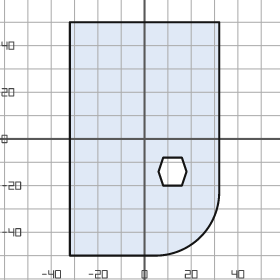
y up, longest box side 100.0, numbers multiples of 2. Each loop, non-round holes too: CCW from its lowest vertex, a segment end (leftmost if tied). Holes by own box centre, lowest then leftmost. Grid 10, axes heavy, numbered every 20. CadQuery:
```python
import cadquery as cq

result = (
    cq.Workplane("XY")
    .moveTo(-32.0, -50.0)
    .lineTo(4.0, -50.0)
    .threePointArc((24.0, -42.0), (32.0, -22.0))
    .lineTo(32.0, 50.0)
    .lineTo(-32.0, 50.0)
    .close()
    .moveTo(8.0, -20.0)
    .lineTo(16.0, -20.0)
    .lineTo(18.0, -14.0)
    .lineTo(16.0, -8.0)
    .lineTo(8.0, -8.0)
    .lineTo(6.0, -14.0)
    .close()
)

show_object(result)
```